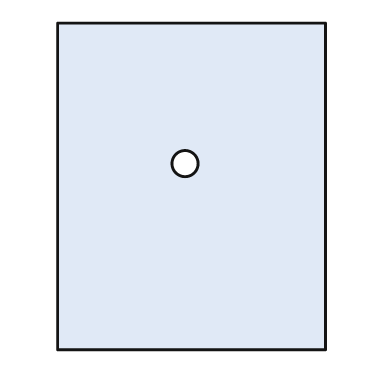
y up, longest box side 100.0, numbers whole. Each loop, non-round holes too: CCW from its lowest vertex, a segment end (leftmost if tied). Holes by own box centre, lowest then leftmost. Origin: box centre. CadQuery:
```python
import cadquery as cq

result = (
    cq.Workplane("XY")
    .moveTo(-41.0, -50.0)
    .lineTo(41.0, -50.0)
    .lineTo(41.0, 50.0)
    .lineTo(-41.0, 50.0)
    .close()
    .moveTo(-2.0, 7.0)
    .circle(4.0)
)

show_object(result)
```